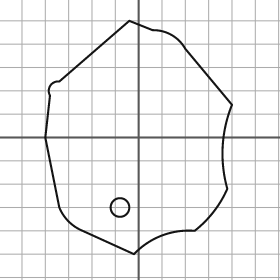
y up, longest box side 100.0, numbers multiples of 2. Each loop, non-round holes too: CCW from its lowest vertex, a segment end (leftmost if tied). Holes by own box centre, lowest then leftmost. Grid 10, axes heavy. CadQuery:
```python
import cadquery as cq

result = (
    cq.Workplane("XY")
    .moveTo(-2.0, -50.0)
    .threePointArc((10.0, -42.0), (24.0, -40.0))
    .threePointArc((32.0, -32.0), (38.0, -22.0))
    .threePointArc((36.0, -4.0), (40.0, 14.0))
    .lineTo(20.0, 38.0)
    .threePointArc((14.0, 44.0), (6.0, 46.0))
    .lineTo(-4.0, 50.0)
    .lineTo(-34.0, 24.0)
    .threePointArc((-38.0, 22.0), (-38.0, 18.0))
    .lineTo(-40.0, 0.0)
    .lineTo(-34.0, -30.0)
    .threePointArc((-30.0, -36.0), (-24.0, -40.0))
    .close()
    .moveTo(-8.0, -30.0)
    .circle(4.0)
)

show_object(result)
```